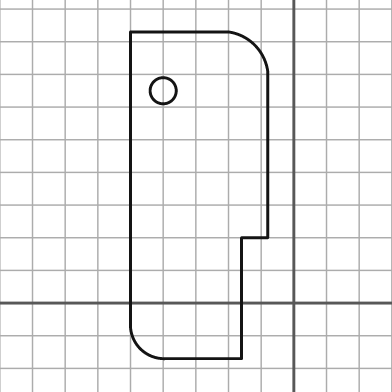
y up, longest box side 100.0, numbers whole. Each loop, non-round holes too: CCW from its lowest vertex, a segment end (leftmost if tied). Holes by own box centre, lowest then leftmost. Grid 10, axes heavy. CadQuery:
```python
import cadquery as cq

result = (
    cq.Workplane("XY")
    .moveTo(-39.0, -17.0)
    .lineTo(-16.0, -17.0)
    .lineTo(-16.0, 20.0)
    .lineTo(-8.0, 20.0)
    .lineTo(-8.0, 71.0)
    .threePointArc((-12.0, 79.0), (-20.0, 83.0))
    .lineTo(-50.0, 83.0)
    .lineTo(-50.0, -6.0)
    .threePointArc((-47.0, -14.0), (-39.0, -17.0))
    .close()
    .moveTo(-40.0, 65.0)
    .circle(4.0)
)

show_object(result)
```